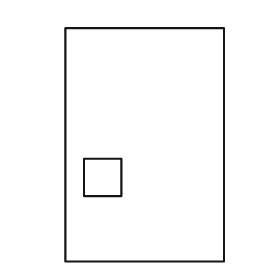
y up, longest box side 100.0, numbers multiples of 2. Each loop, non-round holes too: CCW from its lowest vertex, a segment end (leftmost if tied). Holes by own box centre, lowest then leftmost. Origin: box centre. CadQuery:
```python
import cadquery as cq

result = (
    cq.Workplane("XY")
    .moveTo(-34.0, -50.0)
    .lineTo(34.0, -50.0)
    .lineTo(34.0, 50.0)
    .lineTo(-34.0, 50.0)
    .close()
    .moveTo(-26.0, -22.0)
    .lineTo(-10.0, -22.0)
    .lineTo(-10.0, -6.0)
    .lineTo(-26.0, -6.0)
    .close()
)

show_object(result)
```